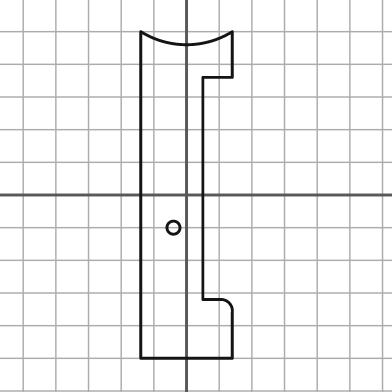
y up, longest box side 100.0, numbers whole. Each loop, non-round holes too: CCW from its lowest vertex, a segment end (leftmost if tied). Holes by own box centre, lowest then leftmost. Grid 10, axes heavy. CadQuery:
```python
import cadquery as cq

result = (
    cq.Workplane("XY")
    .moveTo(-14.0, -50.0)
    .lineTo(14.0, -50.0)
    .lineTo(14.0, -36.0)
    .threePointArc((13.0, -33.0), (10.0, -32.0))
    .lineTo(5.0, -32.0)
    .lineTo(5.0, 36.0)
    .lineTo(14.0, 36.0)
    .lineTo(14.0, 50.0)
    .threePointArc((0.0, 46.0), (-14.0, 50.0))
    .close()
    .moveTo(-4.0, -10.0)
    .circle(2.0)
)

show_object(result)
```